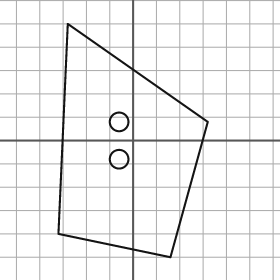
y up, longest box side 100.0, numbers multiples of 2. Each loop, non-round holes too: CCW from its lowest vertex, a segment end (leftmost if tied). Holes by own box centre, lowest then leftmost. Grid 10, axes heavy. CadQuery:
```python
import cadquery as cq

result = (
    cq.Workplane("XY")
    .moveTo(16.0, -50.0)
    .lineTo(32.0, 8.0)
    .lineTo(-28.0, 50.0)
    .lineTo(-32.0, -40.0)
    .close()
    .moveTo(-6.0, -8.0)
    .circle(4.0)
    .moveTo(-6.0, 8.0)
    .circle(4.0)
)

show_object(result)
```